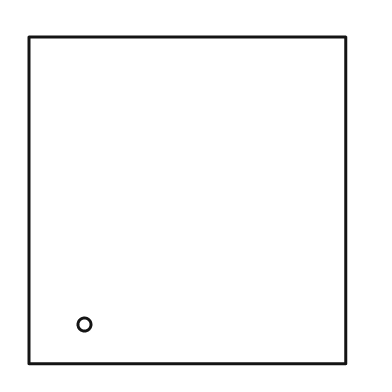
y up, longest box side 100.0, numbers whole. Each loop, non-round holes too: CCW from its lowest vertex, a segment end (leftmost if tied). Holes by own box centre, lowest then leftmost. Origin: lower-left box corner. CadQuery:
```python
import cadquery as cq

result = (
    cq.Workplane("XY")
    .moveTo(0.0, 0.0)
    .lineTo(97.0, 0.0)
    .lineTo(97.0, 100.0)
    .lineTo(0.0, 100.0)
    .close()
    .moveTo(17.0, 12.0)
    .circle(2.0)
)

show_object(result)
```